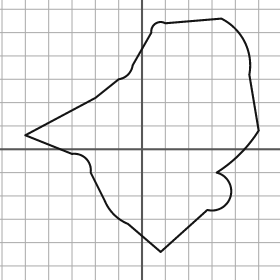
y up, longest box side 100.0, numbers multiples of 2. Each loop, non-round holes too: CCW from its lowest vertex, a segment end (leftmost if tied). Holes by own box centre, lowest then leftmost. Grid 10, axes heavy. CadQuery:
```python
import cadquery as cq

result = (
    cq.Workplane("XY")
    .moveTo(8.0, -44.0)
    .lineTo(28.0, -26.0)
    .threePointArc((38.0, -20.0), (32.0, -10.0))
    .threePointArc((42.0, -2.0), (50.0, 8.0))
    .lineTo(46.0, 32.0)
    .threePointArc((44.0, 46.0), (34.0, 56.0))
    .lineTo(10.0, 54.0)
    .threePointArc((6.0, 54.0), (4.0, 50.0))
    .lineTo(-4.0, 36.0)
    .threePointArc((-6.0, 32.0), (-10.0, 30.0))
    .lineTo(-20.0, 22.0)
    .lineTo(-50.0, 6.0)
    .lineTo(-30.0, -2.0)
    .threePointArc((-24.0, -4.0), (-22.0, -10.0))
    .lineTo(-16.0, -22.0)
    .threePointArc((-12.0, -28.0), (-6.0, -32.0))
    .close()
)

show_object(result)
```